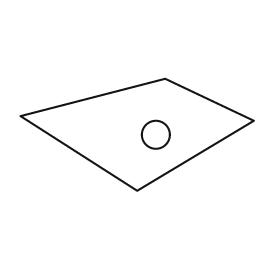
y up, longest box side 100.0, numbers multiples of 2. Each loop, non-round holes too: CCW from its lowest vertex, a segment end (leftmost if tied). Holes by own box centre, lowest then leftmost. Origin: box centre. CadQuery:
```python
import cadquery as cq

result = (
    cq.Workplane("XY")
    .moveTo(0.0, -24.0)
    .lineTo(50.0, 6.0)
    .lineTo(12.0, 24.0)
    .lineTo(-50.0, 8.0)
    .close()
    .moveTo(8.0, 0.0)
    .circle(6.0)
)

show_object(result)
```